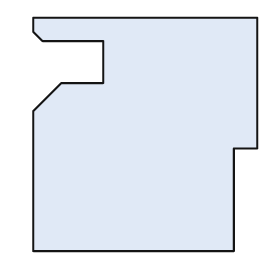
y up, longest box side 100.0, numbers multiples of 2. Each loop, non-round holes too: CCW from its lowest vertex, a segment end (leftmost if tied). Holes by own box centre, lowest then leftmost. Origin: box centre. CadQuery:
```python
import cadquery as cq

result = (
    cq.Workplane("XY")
    .moveTo(-48.0, -50.0)
    .lineTo(38.0, -50.0)
    .lineTo(38.0, -6.0)
    .lineTo(48.0, -6.0)
    .lineTo(48.0, 50.0)
    .lineTo(-48.0, 50.0)
    .lineTo(-48.0, 44.0)
    .lineTo(-44.0, 40.0)
    .lineTo(-18.0, 40.0)
    .lineTo(-18.0, 22.0)
    .lineTo(-36.0, 22.0)
    .lineTo(-48.0, 10.0)
    .close()
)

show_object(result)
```